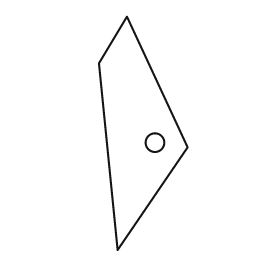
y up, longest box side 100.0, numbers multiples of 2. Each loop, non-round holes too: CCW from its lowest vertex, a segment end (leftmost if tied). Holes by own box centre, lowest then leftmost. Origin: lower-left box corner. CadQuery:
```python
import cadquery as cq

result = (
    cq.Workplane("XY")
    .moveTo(8.0, 0.0)
    .lineTo(38.0, 44.0)
    .lineTo(12.0, 100.0)
    .lineTo(0.0, 80.0)
    .close()
    .moveTo(24.0, 46.0)
    .circle(4.0)
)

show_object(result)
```